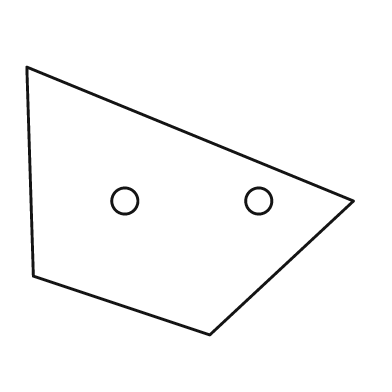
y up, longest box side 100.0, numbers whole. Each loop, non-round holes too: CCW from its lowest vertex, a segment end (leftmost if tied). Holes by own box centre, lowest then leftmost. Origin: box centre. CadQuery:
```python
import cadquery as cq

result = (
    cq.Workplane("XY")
    .moveTo(6.0, -41.0)
    .lineTo(50.0, 0.0)
    .lineTo(-50.0, 41.0)
    .lineTo(-48.0, -23.0)
    .close()
    .moveTo(-20.0, 0.0)
    .circle(4.0)
    .moveTo(21.0, 0.0)
    .circle(4.0)
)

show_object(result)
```